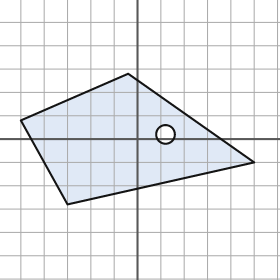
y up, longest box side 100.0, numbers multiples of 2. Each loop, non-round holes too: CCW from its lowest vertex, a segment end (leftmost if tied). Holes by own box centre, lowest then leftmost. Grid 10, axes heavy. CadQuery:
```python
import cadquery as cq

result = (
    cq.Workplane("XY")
    .moveTo(-30.0, -28.0)
    .lineTo(50.0, -10.0)
    .lineTo(-4.0, 28.0)
    .lineTo(-50.0, 8.0)
    .close()
    .moveTo(12.0, 2.0)
    .circle(4.0)
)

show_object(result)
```